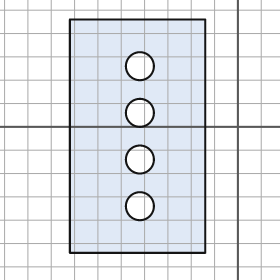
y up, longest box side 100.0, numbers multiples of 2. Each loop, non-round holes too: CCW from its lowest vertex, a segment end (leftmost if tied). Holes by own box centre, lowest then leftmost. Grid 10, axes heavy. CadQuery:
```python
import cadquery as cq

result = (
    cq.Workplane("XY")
    .moveTo(-72.0, -54.0)
    .lineTo(-14.0, -54.0)
    .lineTo(-14.0, 46.0)
    .lineTo(-72.0, 46.0)
    .close()
    .moveTo(-42.0, -34.0)
    .circle(6.0)
    .moveTo(-42.0, -14.0)
    .circle(6.0)
    .moveTo(-42.0, 6.0)
    .circle(6.0)
    .moveTo(-42.0, 26.0)
    .circle(6.0)
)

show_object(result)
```